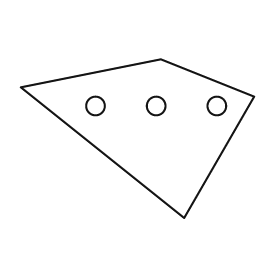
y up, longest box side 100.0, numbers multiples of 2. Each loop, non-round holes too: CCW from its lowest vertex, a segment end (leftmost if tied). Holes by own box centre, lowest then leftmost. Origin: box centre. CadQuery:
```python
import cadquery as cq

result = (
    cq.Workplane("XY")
    .moveTo(20.0, -34.0)
    .lineTo(50.0, 18.0)
    .lineTo(10.0, 34.0)
    .lineTo(-50.0, 22.0)
    .close()
    .moveTo(-18.0, 14.0)
    .circle(4.0)
    .moveTo(8.0, 14.0)
    .circle(4.0)
    .moveTo(34.0, 14.0)
    .circle(4.0)
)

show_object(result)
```